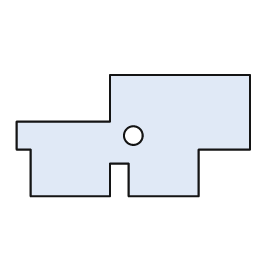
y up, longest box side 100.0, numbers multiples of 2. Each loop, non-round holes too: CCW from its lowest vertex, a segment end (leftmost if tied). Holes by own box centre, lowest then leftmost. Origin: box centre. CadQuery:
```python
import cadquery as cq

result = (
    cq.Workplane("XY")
    .moveTo(-44.0, -26.0)
    .lineTo(-10.0, -26.0)
    .lineTo(-10.0, -12.0)
    .lineTo(-2.0, -12.0)
    .lineTo(-2.0, -26.0)
    .lineTo(28.0, -26.0)
    .lineTo(28.0, -6.0)
    .lineTo(50.0, -6.0)
    .lineTo(50.0, 26.0)
    .lineTo(-10.0, 26.0)
    .lineTo(-10.0, 6.0)
    .lineTo(-50.0, 6.0)
    .lineTo(-50.0, -6.0)
    .lineTo(-44.0, -6.0)
    .close()
    .moveTo(0.0, 0.0)
    .circle(4.0)
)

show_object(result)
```